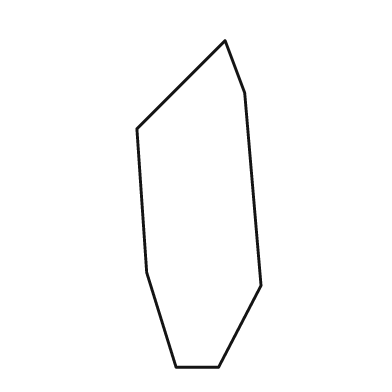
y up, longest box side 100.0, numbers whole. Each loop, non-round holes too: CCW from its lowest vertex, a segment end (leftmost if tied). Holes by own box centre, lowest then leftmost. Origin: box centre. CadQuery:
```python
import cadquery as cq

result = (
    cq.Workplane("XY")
    .moveTo(-7.0, -50.0)
    .lineTo(6.0, -50.0)
    .lineTo(19.0, -25.0)
    .lineTo(14.0, 34.0)
    .lineTo(8.0, 50.0)
    .lineTo(-19.0, 23.0)
    .lineTo(-16.0, -21.0)
    .close()
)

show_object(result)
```